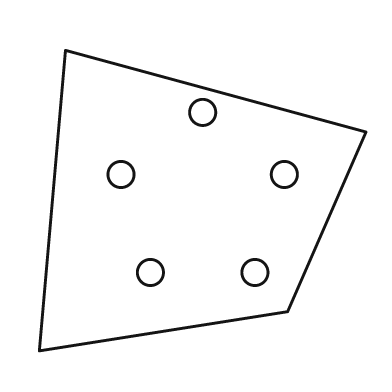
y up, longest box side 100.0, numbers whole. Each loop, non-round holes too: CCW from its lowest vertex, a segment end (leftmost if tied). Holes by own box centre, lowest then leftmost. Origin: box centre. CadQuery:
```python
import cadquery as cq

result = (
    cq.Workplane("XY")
    .moveTo(-50.0, -46.0)
    .lineTo(26.0, -34.0)
    .lineTo(50.0, 21.0)
    .lineTo(-42.0, 46.0)
    .close()
    .moveTo(-16.0, -22.0)
    .circle(4.0)
    .moveTo(16.0, -22.0)
    .circle(4.0)
    .moveTo(-25.0, 8.0)
    .circle(4.0)
    .moveTo(25.0, 8.0)
    .circle(4.0)
    .moveTo(0.0, 27.0)
    .circle(4.0)
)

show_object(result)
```